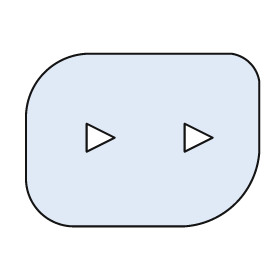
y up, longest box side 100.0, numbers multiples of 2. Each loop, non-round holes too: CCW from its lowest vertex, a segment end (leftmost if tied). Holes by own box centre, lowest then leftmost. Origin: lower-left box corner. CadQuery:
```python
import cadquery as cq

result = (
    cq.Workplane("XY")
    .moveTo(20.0, 0.0)
    .lineTo(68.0, 0.0)
    .threePointArc((90.0, 10.0), (100.0, 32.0))
    .lineTo(100.0, 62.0)
    .threePointArc((96.0, 70.0), (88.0, 74.0))
    .lineTo(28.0, 74.0)
    .threePointArc((8.0, 66.0), (0.0, 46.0))
    .lineTo(0.0, 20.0)
    .threePointArc((6.0, 6.0), (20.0, 0.0))
    .close()
    .moveTo(26.0, 32.0)
    .lineTo(38.0, 38.0)
    .lineTo(26.0, 44.0)
    .close()
    .moveTo(68.0, 32.0)
    .lineTo(80.0, 38.0)
    .lineTo(68.0, 44.0)
    .close()
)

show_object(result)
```